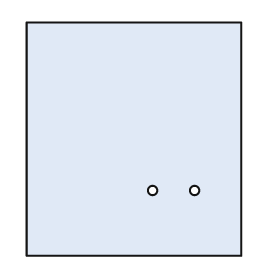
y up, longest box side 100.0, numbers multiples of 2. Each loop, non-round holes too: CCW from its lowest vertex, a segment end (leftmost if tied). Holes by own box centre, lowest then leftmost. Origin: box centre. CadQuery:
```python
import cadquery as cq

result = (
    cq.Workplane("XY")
    .moveTo(-46.0, -50.0)
    .lineTo(46.0, -50.0)
    .lineTo(46.0, 50.0)
    .lineTo(-46.0, 50.0)
    .close()
    .moveTo(8.0, -22.0)
    .circle(2.0)
    .moveTo(26.0, -22.0)
    .circle(2.0)
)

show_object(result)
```